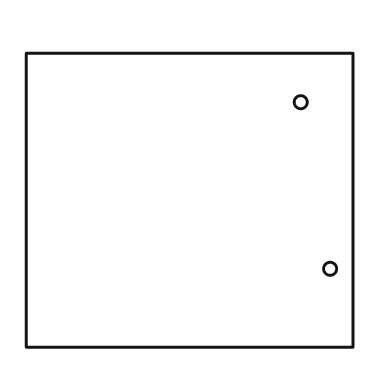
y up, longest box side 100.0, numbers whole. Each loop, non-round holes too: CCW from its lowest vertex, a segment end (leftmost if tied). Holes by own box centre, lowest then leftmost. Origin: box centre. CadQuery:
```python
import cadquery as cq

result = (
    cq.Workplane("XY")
    .moveTo(-50.0, -45.0)
    .lineTo(50.0, -45.0)
    .lineTo(50.0, 45.0)
    .lineTo(-50.0, 45.0)
    .close()
    .moveTo(43.0, -21.0)
    .circle(2.0)
    .moveTo(34.0, 30.0)
    .circle(2.0)
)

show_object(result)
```